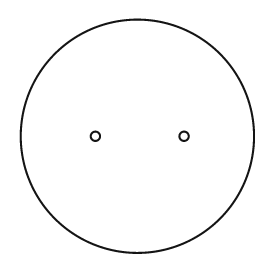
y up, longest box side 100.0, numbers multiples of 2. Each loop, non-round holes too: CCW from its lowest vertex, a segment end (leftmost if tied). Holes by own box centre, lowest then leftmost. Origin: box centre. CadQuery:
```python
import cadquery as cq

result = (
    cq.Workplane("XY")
    .moveTo(0.0, 0.0)
    .circle(50.0)
    .moveTo(-18.0, 0.0)
    .circle(2.0)
    .moveTo(20.0, 0.0)
    .circle(2.0)
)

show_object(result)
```